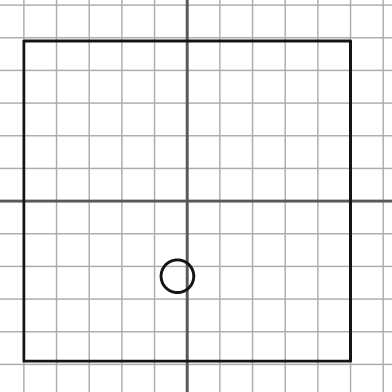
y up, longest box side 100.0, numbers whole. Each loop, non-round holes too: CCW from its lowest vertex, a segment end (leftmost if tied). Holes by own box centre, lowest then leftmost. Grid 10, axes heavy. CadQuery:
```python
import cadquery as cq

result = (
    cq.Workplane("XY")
    .moveTo(-50.0, -49.0)
    .lineTo(50.0, -49.0)
    .lineTo(50.0, 49.0)
    .lineTo(-50.0, 49.0)
    .close()
    .moveTo(-3.0, -23.0)
    .circle(5.0)
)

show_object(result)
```